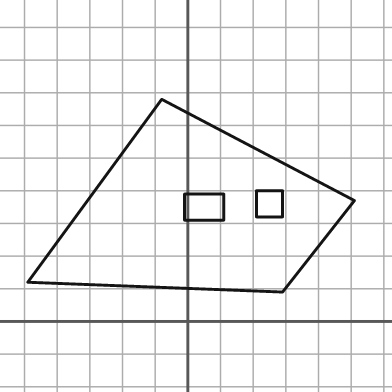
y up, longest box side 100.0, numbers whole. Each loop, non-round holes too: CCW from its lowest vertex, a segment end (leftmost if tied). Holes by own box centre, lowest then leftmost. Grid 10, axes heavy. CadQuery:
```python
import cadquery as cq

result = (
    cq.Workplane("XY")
    .moveTo(29.0, 9.0)
    .lineTo(51.0, 37.0)
    .lineTo(-8.0, 68.0)
    .lineTo(-49.0, 12.0)
    .close()
    .moveTo(-1.0, 31.0)
    .lineTo(11.0, 31.0)
    .lineTo(11.0, 39.0)
    .lineTo(-1.0, 39.0)
    .close()
    .moveTo(21.0, 32.0)
    .lineTo(29.0, 32.0)
    .lineTo(29.0, 40.0)
    .lineTo(21.0, 40.0)
    .close()
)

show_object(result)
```